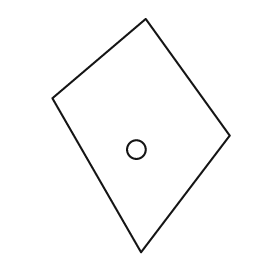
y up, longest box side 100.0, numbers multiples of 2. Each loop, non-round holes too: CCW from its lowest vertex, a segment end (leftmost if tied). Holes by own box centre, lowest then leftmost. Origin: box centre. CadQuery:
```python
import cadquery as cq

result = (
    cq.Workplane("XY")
    .moveTo(0.0, -50.0)
    .lineTo(38.0, 0.0)
    .lineTo(2.0, 50.0)
    .lineTo(-38.0, 16.0)
    .close()
    .moveTo(-2.0, -6.0)
    .circle(4.0)
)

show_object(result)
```